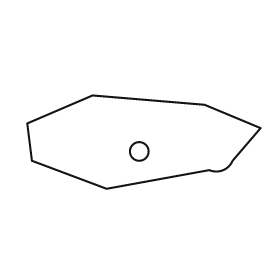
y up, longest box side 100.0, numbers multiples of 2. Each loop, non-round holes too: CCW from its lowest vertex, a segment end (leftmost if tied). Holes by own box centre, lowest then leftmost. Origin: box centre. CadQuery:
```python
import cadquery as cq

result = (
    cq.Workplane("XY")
    .moveTo(-16.0, -20.0)
    .lineTo(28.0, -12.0)
    .threePointArc((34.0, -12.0), (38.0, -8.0))
    .lineTo(50.0, 6.0)
    .lineTo(26.0, 16.0)
    .lineTo(-22.0, 20.0)
    .lineTo(-50.0, 8.0)
    .lineTo(-48.0, -8.0)
    .close()
    .moveTo(-2.0, -4.0)
    .circle(4.0)
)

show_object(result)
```